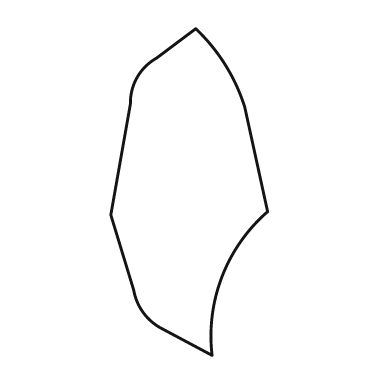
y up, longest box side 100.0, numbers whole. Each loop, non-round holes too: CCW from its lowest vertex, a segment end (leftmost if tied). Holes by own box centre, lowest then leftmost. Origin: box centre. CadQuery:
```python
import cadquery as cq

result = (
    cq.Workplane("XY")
    .moveTo(7.0, -50.0)
    .threePointArc((10.0, -26.0), (24.0, -6.0))
    .lineTo(17.0, 26.0)
    .threePointArc((11.0, 39.0), (2.0, 50.0))
    .lineTo(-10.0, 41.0)
    .threePointArc((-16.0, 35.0), (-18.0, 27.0))
    .lineTo(-24.0, -7.0)
    .lineTo(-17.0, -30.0)
    .threePointArc((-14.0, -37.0), (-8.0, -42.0))
    .close()
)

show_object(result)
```